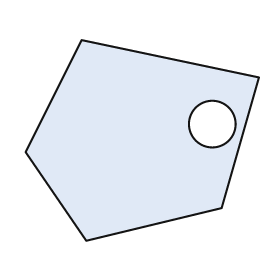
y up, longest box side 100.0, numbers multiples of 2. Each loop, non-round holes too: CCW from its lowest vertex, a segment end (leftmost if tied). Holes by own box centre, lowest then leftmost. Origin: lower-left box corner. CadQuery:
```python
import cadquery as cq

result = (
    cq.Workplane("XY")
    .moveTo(26.0, 0.0)
    .lineTo(84.0, 14.0)
    .lineTo(100.0, 70.0)
    .lineTo(24.0, 86.0)
    .lineTo(0.0, 38.0)
    .close()
    .moveTo(80.0, 50.0)
    .circle(10.0)
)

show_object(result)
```